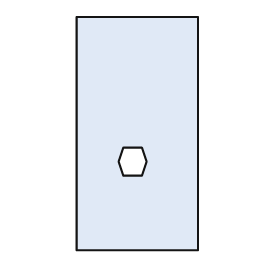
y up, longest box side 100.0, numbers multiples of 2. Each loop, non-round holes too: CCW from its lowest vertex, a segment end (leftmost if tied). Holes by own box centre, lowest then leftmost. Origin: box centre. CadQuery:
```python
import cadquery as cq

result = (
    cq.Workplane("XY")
    .moveTo(-26.0, -50.0)
    .lineTo(26.0, -50.0)
    .lineTo(26.0, 50.0)
    .lineTo(-26.0, 50.0)
    .close()
    .moveTo(-6.0, -18.0)
    .lineTo(2.0, -18.0)
    .lineTo(4.0, -12.0)
    .lineTo(2.0, -6.0)
    .lineTo(-6.0, -6.0)
    .lineTo(-8.0, -12.0)
    .close()
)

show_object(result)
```